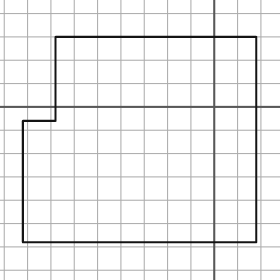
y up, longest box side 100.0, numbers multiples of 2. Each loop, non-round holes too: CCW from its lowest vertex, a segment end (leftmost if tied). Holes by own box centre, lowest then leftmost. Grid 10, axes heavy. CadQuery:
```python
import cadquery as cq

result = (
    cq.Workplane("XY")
    .moveTo(-82.0, -58.0)
    .lineTo(18.0, -58.0)
    .lineTo(18.0, 30.0)
    .lineTo(-68.0, 30.0)
    .lineTo(-68.0, -6.0)
    .lineTo(-82.0, -6.0)
    .close()
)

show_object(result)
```